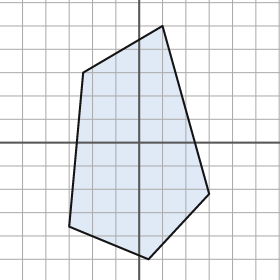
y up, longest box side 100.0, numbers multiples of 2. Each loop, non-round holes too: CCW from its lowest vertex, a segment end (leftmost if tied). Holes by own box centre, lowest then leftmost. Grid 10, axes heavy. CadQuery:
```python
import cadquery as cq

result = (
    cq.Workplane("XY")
    .moveTo(4.0, -50.0)
    .lineTo(30.0, -22.0)
    .lineTo(10.0, 50.0)
    .lineTo(-24.0, 30.0)
    .lineTo(-30.0, -36.0)
    .close()
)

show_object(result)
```